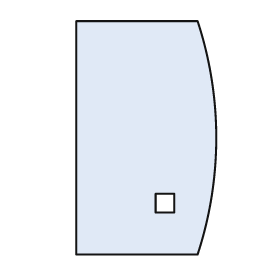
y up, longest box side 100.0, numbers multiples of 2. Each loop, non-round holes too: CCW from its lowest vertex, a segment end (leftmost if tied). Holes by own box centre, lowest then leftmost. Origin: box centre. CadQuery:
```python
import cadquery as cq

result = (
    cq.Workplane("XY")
    .moveTo(-30.0, -50.0)
    .lineTo(22.0, -50.0)
    .threePointArc((30.0, 0.0), (22.0, 50.0))
    .lineTo(-30.0, 50.0)
    .close()
    .moveTo(4.0, -32.0)
    .lineTo(12.0, -32.0)
    .lineTo(12.0, -24.0)
    .lineTo(4.0, -24.0)
    .close()
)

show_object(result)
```